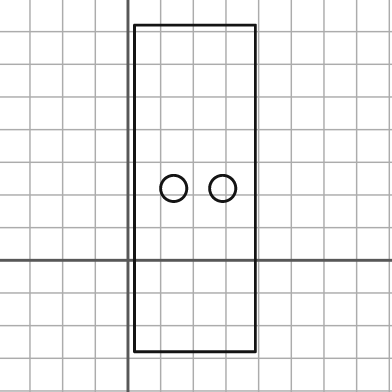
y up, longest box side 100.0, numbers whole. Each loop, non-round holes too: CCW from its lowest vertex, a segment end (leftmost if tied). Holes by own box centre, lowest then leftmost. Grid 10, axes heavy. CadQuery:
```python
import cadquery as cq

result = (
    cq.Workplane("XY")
    .moveTo(2.0, -28.0)
    .lineTo(39.0, -28.0)
    .lineTo(39.0, 72.0)
    .lineTo(2.0, 72.0)
    .close()
    .moveTo(14.0, 22.0)
    .circle(4.0)
    .moveTo(29.0, 22.0)
    .circle(4.0)
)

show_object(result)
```